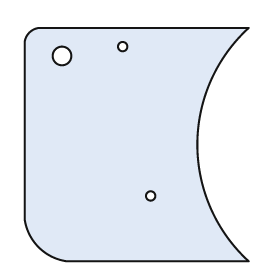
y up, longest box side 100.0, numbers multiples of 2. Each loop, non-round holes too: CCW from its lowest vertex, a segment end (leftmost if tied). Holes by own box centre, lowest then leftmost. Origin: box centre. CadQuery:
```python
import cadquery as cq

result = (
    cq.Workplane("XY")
    .moveTo(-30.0, -50.0)
    .lineTo(48.0, -50.0)
    .threePointArc((26.0, 0.0), (48.0, 50.0))
    .lineTo(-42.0, 50.0)
    .threePointArc((-46.0, 48.0), (-48.0, 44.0))
    .lineTo(-48.0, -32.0)
    .threePointArc((-42.0, -44.0), (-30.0, -50.0))
    .close()
    .moveTo(6.0, -22.0)
    .circle(2.0)
    .moveTo(-32.0, 38.0)
    .circle(4.0)
    .moveTo(-6.0, 42.0)
    .circle(2.0)
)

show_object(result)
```